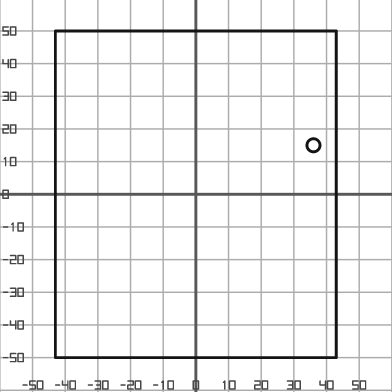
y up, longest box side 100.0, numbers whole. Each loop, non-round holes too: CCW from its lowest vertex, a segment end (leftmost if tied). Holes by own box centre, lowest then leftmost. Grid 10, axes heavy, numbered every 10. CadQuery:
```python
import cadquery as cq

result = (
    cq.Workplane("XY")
    .moveTo(-43.0, -50.0)
    .lineTo(43.0, -50.0)
    .lineTo(43.0, 50.0)
    .lineTo(-43.0, 50.0)
    .close()
    .moveTo(36.0, 15.0)
    .circle(2.0)
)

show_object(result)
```